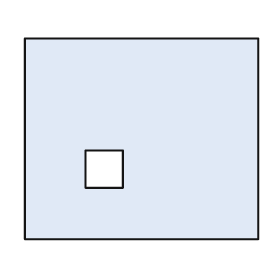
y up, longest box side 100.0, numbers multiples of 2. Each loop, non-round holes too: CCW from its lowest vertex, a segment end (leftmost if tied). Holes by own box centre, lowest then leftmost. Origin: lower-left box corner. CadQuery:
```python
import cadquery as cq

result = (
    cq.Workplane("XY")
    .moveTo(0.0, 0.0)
    .lineTo(100.0, 0.0)
    .lineTo(100.0, 86.0)
    .lineTo(0.0, 86.0)
    .close()
    .moveTo(26.0, 22.0)
    .lineTo(42.0, 22.0)
    .lineTo(42.0, 38.0)
    .lineTo(26.0, 38.0)
    .close()
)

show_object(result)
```